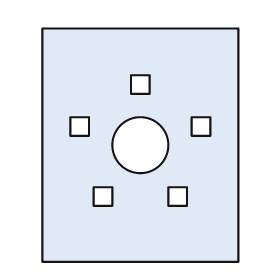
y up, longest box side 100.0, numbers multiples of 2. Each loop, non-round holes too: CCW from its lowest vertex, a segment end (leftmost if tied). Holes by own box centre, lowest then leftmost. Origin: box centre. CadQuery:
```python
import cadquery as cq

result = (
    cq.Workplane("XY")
    .moveTo(-42.0, -50.0)
    .lineTo(42.0, -50.0)
    .lineTo(42.0, 50.0)
    .lineTo(-42.0, 50.0)
    .close()
    .moveTo(-20.0, -26.0)
    .lineTo(-12.0, -26.0)
    .lineTo(-12.0, -18.0)
    .lineTo(-20.0, -18.0)
    .close()
    .moveTo(12.0, -26.0)
    .lineTo(20.0, -26.0)
    .lineTo(20.0, -18.0)
    .lineTo(12.0, -18.0)
    .close()
    .moveTo(0.0, 0.0)
    .circle(12.0)
    .moveTo(-30.0, 4.0)
    .lineTo(-22.0, 4.0)
    .lineTo(-22.0, 12.0)
    .lineTo(-30.0, 12.0)
    .close()
    .moveTo(22.0, 4.0)
    .lineTo(30.0, 4.0)
    .lineTo(30.0, 12.0)
    .lineTo(22.0, 12.0)
    .close()
    .moveTo(-4.0, 22.0)
    .lineTo(4.0, 22.0)
    .lineTo(4.0, 30.0)
    .lineTo(-4.0, 30.0)
    .close()
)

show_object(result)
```